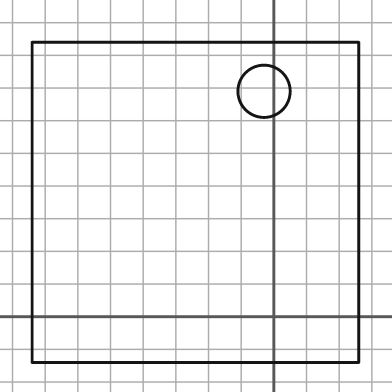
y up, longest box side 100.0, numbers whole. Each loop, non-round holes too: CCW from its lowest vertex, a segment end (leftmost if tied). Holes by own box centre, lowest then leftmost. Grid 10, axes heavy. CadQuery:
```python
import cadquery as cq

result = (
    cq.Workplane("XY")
    .moveTo(-74.0, -14.0)
    .lineTo(26.0, -14.0)
    .lineTo(26.0, 84.0)
    .lineTo(-74.0, 84.0)
    .close()
    .moveTo(-3.0, 69.0)
    .circle(8.0)
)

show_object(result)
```